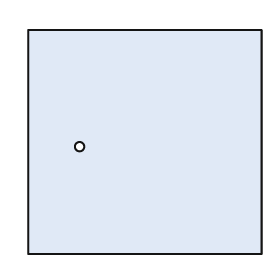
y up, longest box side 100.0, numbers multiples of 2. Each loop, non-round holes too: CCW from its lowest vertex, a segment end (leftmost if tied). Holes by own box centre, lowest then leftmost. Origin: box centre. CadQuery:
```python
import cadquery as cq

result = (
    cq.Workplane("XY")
    .moveTo(-50.0, -48.0)
    .lineTo(50.0, -48.0)
    .lineTo(50.0, 48.0)
    .lineTo(-50.0, 48.0)
    .close()
    .moveTo(-28.0, -2.0)
    .circle(2.0)
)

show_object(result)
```